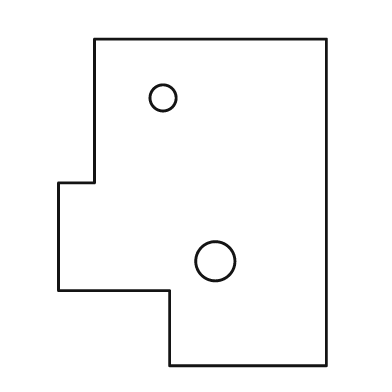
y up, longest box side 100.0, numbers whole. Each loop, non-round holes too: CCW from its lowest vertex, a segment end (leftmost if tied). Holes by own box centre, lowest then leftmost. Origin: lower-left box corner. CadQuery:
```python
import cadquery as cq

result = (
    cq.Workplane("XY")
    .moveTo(34.0, 0.0)
    .lineTo(82.0, 0.0)
    .lineTo(82.0, 100.0)
    .lineTo(11.0, 100.0)
    .lineTo(11.0, 56.0)
    .lineTo(0.0, 56.0)
    .lineTo(0.0, 23.0)
    .lineTo(34.0, 23.0)
    .close()
    .moveTo(48.0, 32.0)
    .circle(6.0)
    .moveTo(32.0, 82.0)
    .circle(4.0)
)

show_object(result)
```